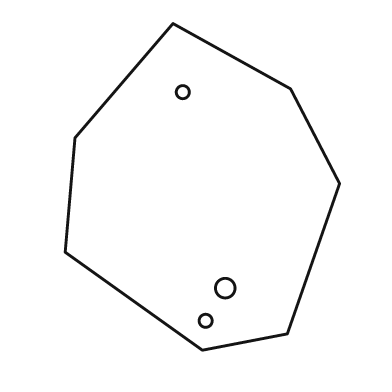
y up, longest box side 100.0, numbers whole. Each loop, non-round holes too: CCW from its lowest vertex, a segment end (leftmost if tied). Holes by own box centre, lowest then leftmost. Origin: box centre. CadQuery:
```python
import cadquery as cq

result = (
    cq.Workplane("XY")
    .moveTo(0.0, -50.0)
    .lineTo(26.0, -45.0)
    .lineTo(42.0, 1.0)
    .lineTo(27.0, 30.0)
    .lineTo(-9.0, 50.0)
    .lineTo(-39.0, 15.0)
    .lineTo(-42.0, -20.0)
    .close()
    .moveTo(1.0, -41.0)
    .circle(2.0)
    .moveTo(7.0, -31.0)
    .circle(3.0)
    .moveTo(-6.0, 29.0)
    .circle(2.0)
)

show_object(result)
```